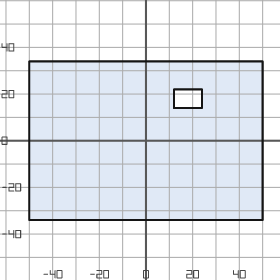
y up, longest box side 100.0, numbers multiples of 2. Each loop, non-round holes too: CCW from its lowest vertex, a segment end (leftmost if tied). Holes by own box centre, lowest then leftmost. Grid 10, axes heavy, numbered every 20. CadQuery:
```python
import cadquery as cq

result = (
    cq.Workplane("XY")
    .moveTo(-50.0, -34.0)
    .lineTo(50.0, -34.0)
    .lineTo(50.0, 34.0)
    .lineTo(-50.0, 34.0)
    .close()
    .moveTo(12.0, 14.0)
    .lineTo(24.0, 14.0)
    .lineTo(24.0, 22.0)
    .lineTo(12.0, 22.0)
    .close()
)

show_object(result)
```